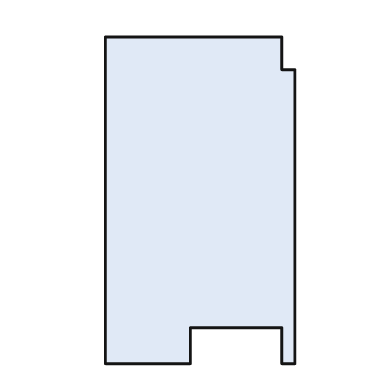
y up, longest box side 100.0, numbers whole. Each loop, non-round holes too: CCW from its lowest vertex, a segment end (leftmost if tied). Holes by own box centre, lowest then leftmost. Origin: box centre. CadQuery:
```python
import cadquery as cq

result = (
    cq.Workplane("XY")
    .moveTo(-29.0, -50.0)
    .lineTo(-3.0, -50.0)
    .lineTo(-3.0, -39.0)
    .lineTo(25.0, -39.0)
    .lineTo(25.0, -50.0)
    .lineTo(29.0, -50.0)
    .lineTo(29.0, 40.0)
    .lineTo(25.0, 40.0)
    .lineTo(25.0, 50.0)
    .lineTo(-29.0, 50.0)
    .close()
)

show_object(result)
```